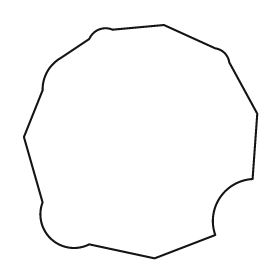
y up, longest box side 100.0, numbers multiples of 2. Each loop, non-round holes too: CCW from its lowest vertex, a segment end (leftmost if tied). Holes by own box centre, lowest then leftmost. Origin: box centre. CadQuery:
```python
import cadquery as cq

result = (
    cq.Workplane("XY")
    .moveTo(6.0, -50.0)
    .lineTo(32.0, -40.0)
    .threePointArc((34.0, -24.0), (48.0, -16.0))
    .lineTo(50.0, 12.0)
    .lineTo(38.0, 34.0)
    .threePointArc((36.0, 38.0), (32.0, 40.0))
    .lineTo(10.0, 50.0)
    .lineTo(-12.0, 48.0)
    .threePointArc((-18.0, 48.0), (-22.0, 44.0))
    .lineTo(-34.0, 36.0)
    .threePointArc((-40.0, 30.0), (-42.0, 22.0))
    .lineTo(-50.0, 2.0)
    .lineTo(-42.0, -26.0)
    .threePointArc((-38.0, -42.0), (-22.0, -44.0))
    .close()
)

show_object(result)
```